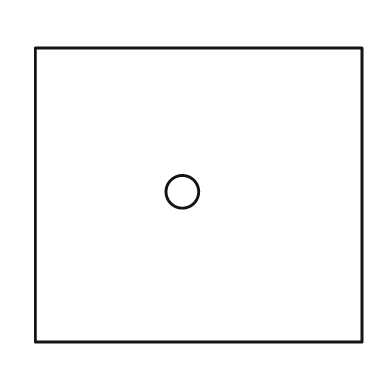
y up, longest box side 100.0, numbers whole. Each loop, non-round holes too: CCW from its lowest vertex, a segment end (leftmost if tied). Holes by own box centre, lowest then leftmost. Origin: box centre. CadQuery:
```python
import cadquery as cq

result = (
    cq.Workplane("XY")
    .moveTo(-50.0, -45.0)
    .lineTo(50.0, -45.0)
    .lineTo(50.0, 45.0)
    .lineTo(-50.0, 45.0)
    .close()
    .moveTo(-5.0, 1.0)
    .circle(5.0)
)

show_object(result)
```